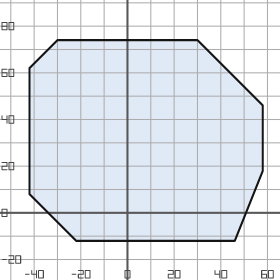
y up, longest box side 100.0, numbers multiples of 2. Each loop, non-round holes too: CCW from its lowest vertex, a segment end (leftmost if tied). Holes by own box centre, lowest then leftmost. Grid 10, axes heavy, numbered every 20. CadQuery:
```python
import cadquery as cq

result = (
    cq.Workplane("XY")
    .moveTo(-22.0, -12.0)
    .lineTo(46.0, -12.0)
    .lineTo(58.0, 18.0)
    .lineTo(58.0, 46.0)
    .lineTo(30.0, 74.0)
    .lineTo(-30.0, 74.0)
    .lineTo(-42.0, 62.0)
    .lineTo(-42.0, 8.0)
    .close()
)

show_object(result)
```